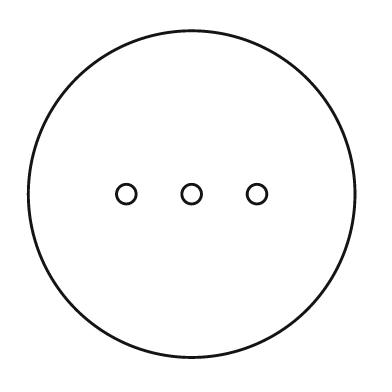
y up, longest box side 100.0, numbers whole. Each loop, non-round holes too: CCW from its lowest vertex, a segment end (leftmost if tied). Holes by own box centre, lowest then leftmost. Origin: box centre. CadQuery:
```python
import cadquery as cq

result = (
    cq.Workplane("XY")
    .moveTo(0.0, 0.0)
    .circle(50.0)
    .moveTo(-20.0, 0.0)
    .circle(3.0)
    .moveTo(0.0, 0.0)
    .circle(3.0)
    .moveTo(20.0, 0.0)
    .circle(3.0)
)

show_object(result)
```